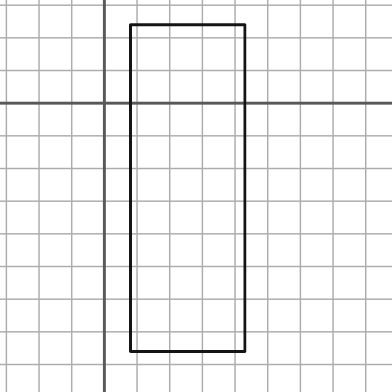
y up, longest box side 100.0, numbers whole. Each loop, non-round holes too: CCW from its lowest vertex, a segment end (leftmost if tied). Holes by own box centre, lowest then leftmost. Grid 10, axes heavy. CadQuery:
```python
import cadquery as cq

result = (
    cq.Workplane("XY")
    .moveTo(8.0, -76.0)
    .lineTo(43.0, -76.0)
    .lineTo(43.0, 24.0)
    .lineTo(8.0, 24.0)
    .close()
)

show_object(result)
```